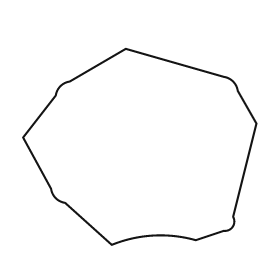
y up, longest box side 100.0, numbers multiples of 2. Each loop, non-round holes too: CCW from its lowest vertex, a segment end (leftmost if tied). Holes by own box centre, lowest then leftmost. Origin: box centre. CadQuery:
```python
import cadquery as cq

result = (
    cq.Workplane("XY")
    .moveTo(-12.0, -42.0)
    .threePointArc((6.0, -38.0), (24.0, -40.0))
    .lineTo(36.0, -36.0)
    .threePointArc((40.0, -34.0), (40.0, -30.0))
    .lineTo(50.0, 10.0)
    .lineTo(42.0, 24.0)
    .threePointArc((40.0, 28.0), (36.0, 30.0))
    .lineTo(-6.0, 42.0)
    .lineTo(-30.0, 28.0)
    .threePointArc((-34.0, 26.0), (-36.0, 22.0))
    .lineTo(-50.0, 4.0)
    .lineTo(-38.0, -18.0)
    .threePointArc((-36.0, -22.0), (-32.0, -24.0))
    .close()
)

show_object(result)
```